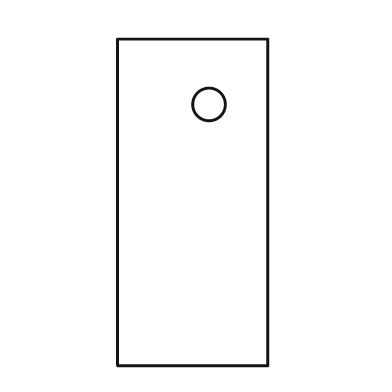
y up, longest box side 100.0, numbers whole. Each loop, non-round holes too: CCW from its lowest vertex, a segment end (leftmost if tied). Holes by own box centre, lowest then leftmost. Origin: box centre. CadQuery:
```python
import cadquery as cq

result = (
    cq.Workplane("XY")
    .moveTo(-23.0, -50.0)
    .lineTo(23.0, -50.0)
    .lineTo(23.0, 50.0)
    .lineTo(-23.0, 50.0)
    .close()
    .moveTo(5.0, 30.0)
    .circle(5.0)
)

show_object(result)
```